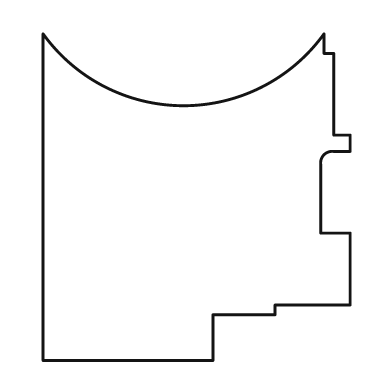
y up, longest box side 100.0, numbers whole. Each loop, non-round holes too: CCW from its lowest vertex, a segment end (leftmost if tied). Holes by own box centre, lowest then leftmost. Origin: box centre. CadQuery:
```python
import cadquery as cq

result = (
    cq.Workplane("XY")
    .moveTo(-47.0, -50.0)
    .lineTo(5.0, -50.0)
    .lineTo(5.0, -36.0)
    .lineTo(24.0, -36.0)
    .lineTo(24.0, -33.0)
    .lineTo(47.0, -33.0)
    .lineTo(47.0, -11.0)
    .lineTo(38.0, -11.0)
    .lineTo(38.0, 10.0)
    .threePointArc((39.0, 13.0), (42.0, 14.0))
    .lineTo(47.0, 14.0)
    .lineTo(47.0, 19.0)
    .lineTo(42.0, 19.0)
    .lineTo(42.0, 44.0)
    .lineTo(39.0, 44.0)
    .lineTo(39.0, 50.0)
    .threePointArc((-4.0, 28.0), (-47.0, 50.0))
    .close()
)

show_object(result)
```